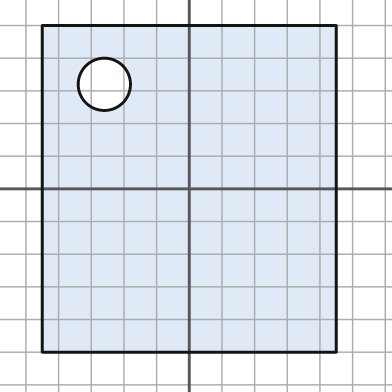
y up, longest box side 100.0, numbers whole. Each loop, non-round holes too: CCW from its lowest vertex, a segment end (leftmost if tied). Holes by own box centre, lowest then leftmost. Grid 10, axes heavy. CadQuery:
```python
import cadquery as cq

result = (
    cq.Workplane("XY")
    .moveTo(-45.0, -50.0)
    .lineTo(45.0, -50.0)
    .lineTo(45.0, 50.0)
    .lineTo(-45.0, 50.0)
    .close()
    .moveTo(-26.0, 32.0)
    .circle(8.0)
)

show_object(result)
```